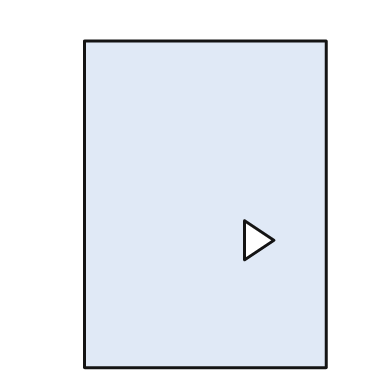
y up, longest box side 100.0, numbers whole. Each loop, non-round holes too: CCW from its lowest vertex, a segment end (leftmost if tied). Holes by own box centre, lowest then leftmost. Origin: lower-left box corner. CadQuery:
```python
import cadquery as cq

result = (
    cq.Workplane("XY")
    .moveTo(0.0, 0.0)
    .lineTo(74.0, 0.0)
    .lineTo(74.0, 100.0)
    .lineTo(0.0, 100.0)
    .close()
    .moveTo(49.0, 33.0)
    .lineTo(58.0, 39.0)
    .lineTo(49.0, 45.0)
    .close()
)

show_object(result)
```